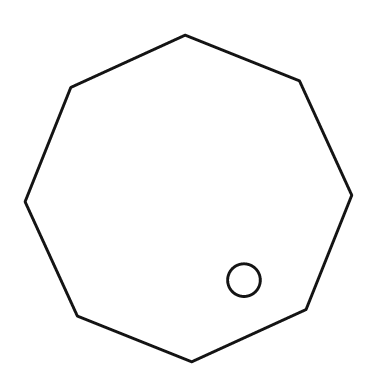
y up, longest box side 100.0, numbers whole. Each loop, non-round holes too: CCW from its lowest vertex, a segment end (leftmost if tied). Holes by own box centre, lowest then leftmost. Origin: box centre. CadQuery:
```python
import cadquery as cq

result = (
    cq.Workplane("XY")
    .moveTo(1.0, -50.0)
    .lineTo(36.0, -34.0)
    .lineTo(50.0, 1.0)
    .lineTo(34.0, 36.0)
    .lineTo(-1.0, 50.0)
    .lineTo(-36.0, 34.0)
    .lineTo(-50.0, -1.0)
    .lineTo(-34.0, -36.0)
    .close()
    .moveTo(17.0, -25.0)
    .circle(5.0)
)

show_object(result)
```